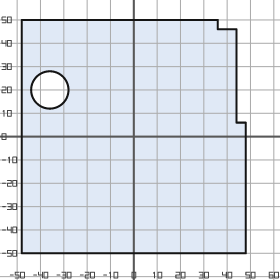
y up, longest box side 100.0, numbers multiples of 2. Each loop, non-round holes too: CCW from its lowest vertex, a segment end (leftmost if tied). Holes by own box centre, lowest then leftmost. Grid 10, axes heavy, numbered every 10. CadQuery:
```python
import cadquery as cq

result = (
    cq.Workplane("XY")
    .moveTo(-48.0, -50.0)
    .lineTo(48.0, -50.0)
    .lineTo(48.0, 6.0)
    .lineTo(44.0, 6.0)
    .lineTo(44.0, 46.0)
    .lineTo(36.0, 46.0)
    .lineTo(36.0, 50.0)
    .lineTo(-48.0, 50.0)
    .close()
    .moveTo(-36.0, 20.0)
    .circle(8.0)
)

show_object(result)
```